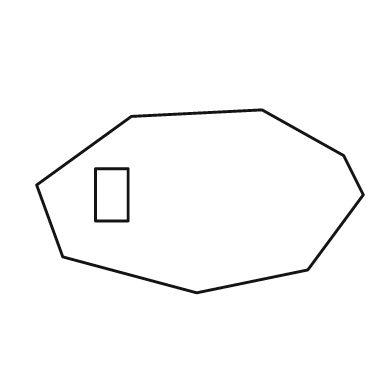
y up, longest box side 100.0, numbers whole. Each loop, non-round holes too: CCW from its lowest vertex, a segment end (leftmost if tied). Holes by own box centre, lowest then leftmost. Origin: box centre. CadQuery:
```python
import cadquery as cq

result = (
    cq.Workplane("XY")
    .moveTo(-1.0, -28.0)
    .lineTo(33.0, -21.0)
    .lineTo(50.0, 2.0)
    .lineTo(44.0, 14.0)
    .lineTo(19.0, 28.0)
    .lineTo(-21.0, 26.0)
    .lineTo(-50.0, 5.0)
    .lineTo(-42.0, -17.0)
    .close()
    .moveTo(-32.0, -6.0)
    .lineTo(-22.0, -6.0)
    .lineTo(-22.0, 10.0)
    .lineTo(-32.0, 10.0)
    .close()
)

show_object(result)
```